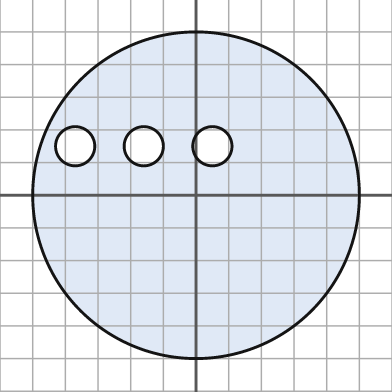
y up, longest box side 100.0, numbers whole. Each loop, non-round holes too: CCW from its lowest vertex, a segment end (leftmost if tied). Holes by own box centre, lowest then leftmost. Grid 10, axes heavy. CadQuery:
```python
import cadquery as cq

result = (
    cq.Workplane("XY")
    .moveTo(0.0, 0.0)
    .circle(50.0)
    .moveTo(-37.0, 15.0)
    .circle(6.0)
    .moveTo(-16.0, 15.0)
    .circle(6.0)
    .moveTo(5.0, 15.0)
    .circle(6.0)
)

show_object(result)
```